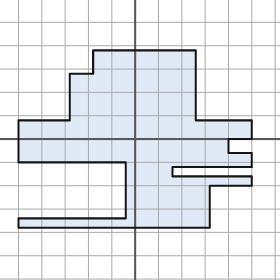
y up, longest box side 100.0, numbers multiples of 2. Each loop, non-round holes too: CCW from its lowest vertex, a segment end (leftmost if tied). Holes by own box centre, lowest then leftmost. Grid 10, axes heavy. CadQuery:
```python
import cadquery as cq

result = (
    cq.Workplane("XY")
    .moveTo(-50.0, -38.0)
    .lineTo(32.0, -38.0)
    .lineTo(32.0, -20.0)
    .lineTo(50.0, -20.0)
    .lineTo(50.0, -16.0)
    .lineTo(16.0, -16.0)
    .lineTo(16.0, -12.0)
    .lineTo(50.0, -12.0)
    .lineTo(50.0, -6.0)
    .lineTo(40.0, -6.0)
    .lineTo(40.0, 0.0)
    .lineTo(50.0, 0.0)
    .lineTo(50.0, 8.0)
    .lineTo(26.0, 8.0)
    .lineTo(26.0, 38.0)
    .lineTo(-18.0, 38.0)
    .lineTo(-18.0, 28.0)
    .lineTo(-28.0, 28.0)
    .lineTo(-28.0, 8.0)
    .lineTo(-50.0, 8.0)
    .lineTo(-50.0, -10.0)
    .lineTo(-4.0, -10.0)
    .lineTo(-4.0, -34.0)
    .lineTo(-50.0, -34.0)
    .close()
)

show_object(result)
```